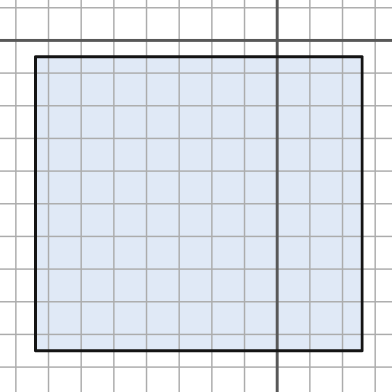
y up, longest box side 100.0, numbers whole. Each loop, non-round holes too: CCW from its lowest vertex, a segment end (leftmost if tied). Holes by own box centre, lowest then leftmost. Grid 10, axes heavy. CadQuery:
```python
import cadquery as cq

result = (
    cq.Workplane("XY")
    .moveTo(-74.0, -95.0)
    .lineTo(26.0, -95.0)
    .lineTo(26.0, -5.0)
    .lineTo(-74.0, -5.0)
    .close()
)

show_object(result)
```